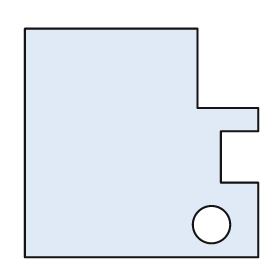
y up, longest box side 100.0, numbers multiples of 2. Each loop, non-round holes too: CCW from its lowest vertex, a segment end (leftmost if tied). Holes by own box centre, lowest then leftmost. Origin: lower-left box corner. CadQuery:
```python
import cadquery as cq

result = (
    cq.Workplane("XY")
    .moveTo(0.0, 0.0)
    .lineTo(100.0, 0.0)
    .lineTo(100.0, 32.0)
    .lineTo(84.0, 32.0)
    .lineTo(84.0, 54.0)
    .lineTo(100.0, 54.0)
    .lineTo(100.0, 64.0)
    .lineTo(74.0, 64.0)
    .lineTo(74.0, 98.0)
    .lineTo(0.0, 98.0)
    .close()
    .moveTo(80.0, 14.0)
    .circle(8.0)
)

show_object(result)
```